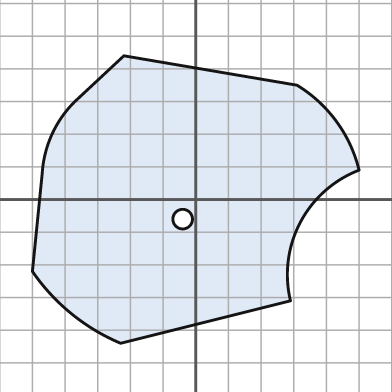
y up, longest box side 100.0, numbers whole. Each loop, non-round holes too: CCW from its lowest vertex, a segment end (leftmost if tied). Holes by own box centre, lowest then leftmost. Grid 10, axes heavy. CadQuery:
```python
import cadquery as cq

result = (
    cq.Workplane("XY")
    .moveTo(-23.0, -44.0)
    .lineTo(29.0, -31.0)
    .threePointArc((32.0, -7.0), (50.0, 9.0))
    .threePointArc((43.0, 24.0), (31.0, 35.0))
    .lineTo(-22.0, 44.0)
    .lineTo(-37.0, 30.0)
    .threePointArc((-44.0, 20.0), (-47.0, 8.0))
    .lineTo(-50.0, -22.0)
    .threePointArc((-38.0, -35.0), (-23.0, -44.0))
    .close()
    .moveTo(-4.0, -6.0)
    .circle(3.0)
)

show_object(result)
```